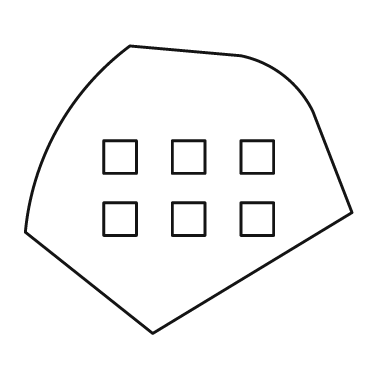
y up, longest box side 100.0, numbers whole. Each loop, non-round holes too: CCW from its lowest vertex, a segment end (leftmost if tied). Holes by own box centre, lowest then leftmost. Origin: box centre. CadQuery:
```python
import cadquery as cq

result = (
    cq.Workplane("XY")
    .moveTo(-11.0, -44.0)
    .lineTo(50.0, -7.0)
    .lineTo(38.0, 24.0)
    .threePointArc((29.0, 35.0), (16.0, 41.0))
    .lineTo(-18.0, 44.0)
    .threePointArc((-40.0, 19.0), (-50.0, -13.0))
    .close()
    .moveTo(-26.0, -14.0)
    .lineTo(-16.0, -14.0)
    .lineTo(-16.0, -4.0)
    .lineTo(-26.0, -4.0)
    .close()
    .moveTo(-5.0, -14.0)
    .lineTo(5.0, -14.0)
    .lineTo(5.0, -4.0)
    .lineTo(-5.0, -4.0)
    .close()
    .moveTo(16.0, -14.0)
    .lineTo(26.0, -14.0)
    .lineTo(26.0, -4.0)
    .lineTo(16.0, -4.0)
    .close()
    .moveTo(-26.0, 5.0)
    .lineTo(-16.0, 5.0)
    .lineTo(-16.0, 15.0)
    .lineTo(-26.0, 15.0)
    .close()
    .moveTo(-5.0, 5.0)
    .lineTo(5.0, 5.0)
    .lineTo(5.0, 15.0)
    .lineTo(-5.0, 15.0)
    .close()
    .moveTo(16.0, 5.0)
    .lineTo(26.0, 5.0)
    .lineTo(26.0, 15.0)
    .lineTo(16.0, 15.0)
    .close()
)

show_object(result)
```